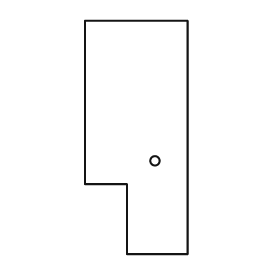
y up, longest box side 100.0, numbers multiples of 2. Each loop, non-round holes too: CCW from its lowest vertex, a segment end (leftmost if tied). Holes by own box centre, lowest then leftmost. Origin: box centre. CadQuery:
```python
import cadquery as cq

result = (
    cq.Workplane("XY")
    .moveTo(-4.0, -50.0)
    .lineTo(22.0, -50.0)
    .lineTo(22.0, 50.0)
    .lineTo(-22.0, 50.0)
    .lineTo(-22.0, -20.0)
    .lineTo(-4.0, -20.0)
    .close()
    .moveTo(8.0, -10.0)
    .circle(2.0)
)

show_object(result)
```